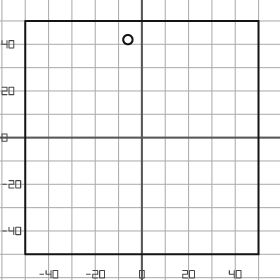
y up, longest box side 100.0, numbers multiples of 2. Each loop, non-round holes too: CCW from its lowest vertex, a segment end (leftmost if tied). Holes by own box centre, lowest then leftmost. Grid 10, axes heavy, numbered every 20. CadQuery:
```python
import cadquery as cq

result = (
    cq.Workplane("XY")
    .moveTo(-50.0, -50.0)
    .lineTo(50.0, -50.0)
    .lineTo(50.0, 50.0)
    .lineTo(-50.0, 50.0)
    .close()
    .moveTo(-6.0, 42.0)
    .circle(2.0)
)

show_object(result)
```